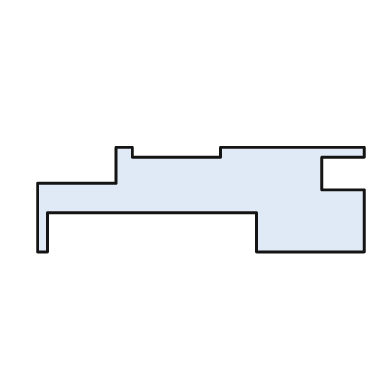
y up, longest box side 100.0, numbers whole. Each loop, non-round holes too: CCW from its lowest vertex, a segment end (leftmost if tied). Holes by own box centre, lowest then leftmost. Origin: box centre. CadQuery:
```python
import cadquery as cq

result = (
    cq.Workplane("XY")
    .moveTo(-50.0, -16.0)
    .lineTo(-47.0, -16.0)
    .lineTo(-47.0, -4.0)
    .lineTo(17.0, -4.0)
    .lineTo(17.0, -16.0)
    .lineTo(50.0, -16.0)
    .lineTo(50.0, 3.0)
    .lineTo(37.0, 3.0)
    .lineTo(37.0, 13.0)
    .lineTo(50.0, 13.0)
    .lineTo(50.0, 16.0)
    .lineTo(6.0, 16.0)
    .lineTo(6.0, 13.0)
    .lineTo(-21.0, 13.0)
    .lineTo(-21.0, 16.0)
    .lineTo(-26.0, 16.0)
    .lineTo(-26.0, 5.0)
    .lineTo(-50.0, 5.0)
    .close()
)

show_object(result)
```